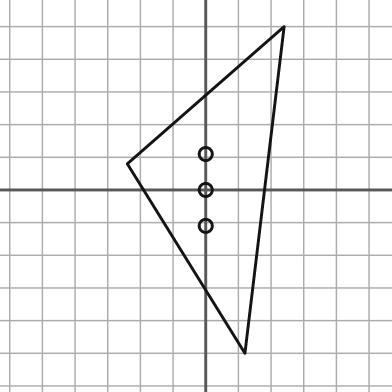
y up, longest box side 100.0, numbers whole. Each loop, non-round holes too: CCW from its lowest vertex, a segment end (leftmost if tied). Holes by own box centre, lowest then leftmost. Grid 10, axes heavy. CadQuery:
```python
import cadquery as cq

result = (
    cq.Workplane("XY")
    .moveTo(12.0, -50.0)
    .lineTo(24.0, 50.0)
    .lineTo(-24.0, 8.0)
    .close()
    .moveTo(0.0, -11.0)
    .circle(2.0)
    .moveTo(0.0, 0.0)
    .circle(2.0)
    .moveTo(0.0, 11.0)
    .circle(2.0)
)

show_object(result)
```